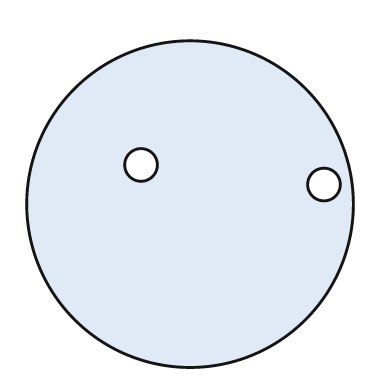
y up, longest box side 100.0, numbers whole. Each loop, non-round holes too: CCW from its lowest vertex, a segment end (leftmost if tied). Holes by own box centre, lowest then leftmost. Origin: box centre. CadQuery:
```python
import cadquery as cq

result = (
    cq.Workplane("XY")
    .moveTo(0.0, 0.0)
    .circle(50.0)
    .moveTo(41.0, 6.0)
    .circle(5.0)
    .moveTo(-15.0, 12.0)
    .circle(5.0)
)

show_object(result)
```